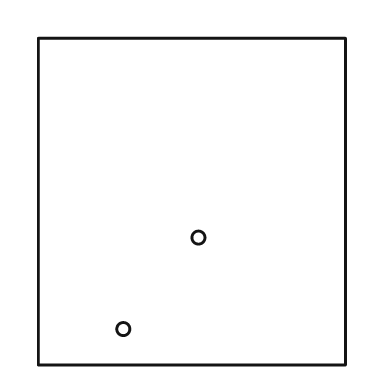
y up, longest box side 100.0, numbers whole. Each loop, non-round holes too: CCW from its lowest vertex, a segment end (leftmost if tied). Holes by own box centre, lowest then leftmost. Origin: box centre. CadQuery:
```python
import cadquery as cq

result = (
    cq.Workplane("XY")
    .moveTo(-47.0, -50.0)
    .lineTo(47.0, -50.0)
    .lineTo(47.0, 50.0)
    .lineTo(-47.0, 50.0)
    .close()
    .moveTo(-21.0, -39.0)
    .circle(2.0)
    .moveTo(2.0, -11.0)
    .circle(2.0)
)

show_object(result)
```